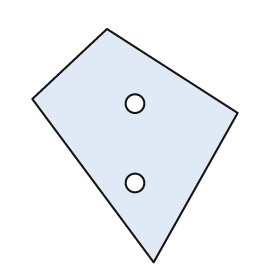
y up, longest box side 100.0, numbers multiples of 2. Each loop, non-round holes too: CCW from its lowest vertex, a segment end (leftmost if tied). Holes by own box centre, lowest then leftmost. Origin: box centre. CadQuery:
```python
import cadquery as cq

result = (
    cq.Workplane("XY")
    .moveTo(8.0, -50.0)
    .lineTo(44.0, 14.0)
    .lineTo(-12.0, 50.0)
    .lineTo(-44.0, 20.0)
    .close()
    .moveTo(0.0, -16.0)
    .circle(4.0)
    .moveTo(0.0, 18.0)
    .circle(4.0)
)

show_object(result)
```